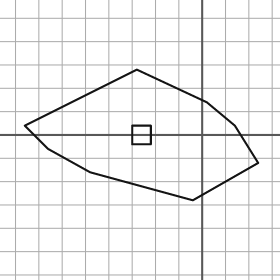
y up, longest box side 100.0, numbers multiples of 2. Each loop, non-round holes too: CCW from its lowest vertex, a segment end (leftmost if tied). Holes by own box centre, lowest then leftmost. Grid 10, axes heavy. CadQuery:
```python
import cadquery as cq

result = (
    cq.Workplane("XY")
    .moveTo(-4.0, -28.0)
    .lineTo(24.0, -12.0)
    .lineTo(14.0, 4.0)
    .lineTo(2.0, 14.0)
    .lineTo(-28.0, 28.0)
    .lineTo(-76.0, 4.0)
    .lineTo(-66.0, -6.0)
    .lineTo(-48.0, -16.0)
    .close()
    .moveTo(-30.0, -4.0)
    .lineTo(-22.0, -4.0)
    .lineTo(-22.0, 4.0)
    .lineTo(-30.0, 4.0)
    .close()
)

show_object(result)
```